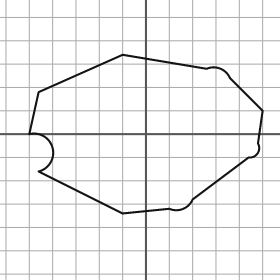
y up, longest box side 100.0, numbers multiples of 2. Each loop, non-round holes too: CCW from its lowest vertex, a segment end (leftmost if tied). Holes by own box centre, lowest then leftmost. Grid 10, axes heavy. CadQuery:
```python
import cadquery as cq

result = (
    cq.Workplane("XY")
    .moveTo(-10.0, -34.0)
    .lineTo(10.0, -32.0)
    .threePointArc((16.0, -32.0), (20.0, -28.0))
    .lineTo(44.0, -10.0)
    .threePointArc((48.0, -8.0), (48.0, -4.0))
    .lineTo(50.0, 10.0)
    .lineTo(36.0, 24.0)
    .threePointArc((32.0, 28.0), (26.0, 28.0))
    .lineTo(-10.0, 34.0)
    .lineTo(-46.0, 18.0)
    .lineTo(-50.0, 0.0)
    .threePointArc((-40.0, -6.0), (-46.0, -16.0))
    .close()
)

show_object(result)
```